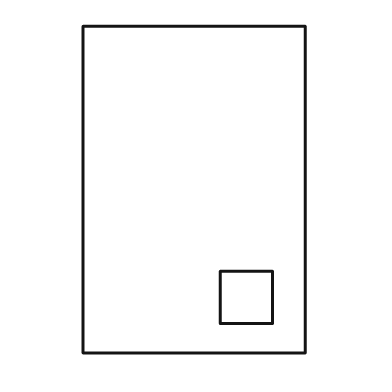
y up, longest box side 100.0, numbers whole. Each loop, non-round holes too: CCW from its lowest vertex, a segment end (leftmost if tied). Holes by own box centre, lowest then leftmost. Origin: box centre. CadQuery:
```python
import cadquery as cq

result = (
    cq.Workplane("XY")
    .moveTo(-34.0, -50.0)
    .lineTo(34.0, -50.0)
    .lineTo(34.0, 50.0)
    .lineTo(-34.0, 50.0)
    .close()
    .moveTo(8.0, -41.0)
    .lineTo(24.0, -41.0)
    .lineTo(24.0, -25.0)
    .lineTo(8.0, -25.0)
    .close()
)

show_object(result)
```